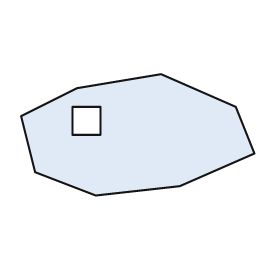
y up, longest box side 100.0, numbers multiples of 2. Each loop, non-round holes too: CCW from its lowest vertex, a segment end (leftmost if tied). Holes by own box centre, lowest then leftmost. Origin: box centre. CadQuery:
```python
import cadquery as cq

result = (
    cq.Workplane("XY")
    .moveTo(-18.0, -26.0)
    .lineTo(18.0, -22.0)
    .lineTo(50.0, -8.0)
    .lineTo(42.0, 12.0)
    .lineTo(10.0, 26.0)
    .lineTo(-26.0, 20.0)
    .lineTo(-50.0, 8.0)
    .lineTo(-44.0, -16.0)
    .close()
    .moveTo(-28.0, 0.0)
    .lineTo(-16.0, 0.0)
    .lineTo(-16.0, 12.0)
    .lineTo(-28.0, 12.0)
    .close()
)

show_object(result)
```